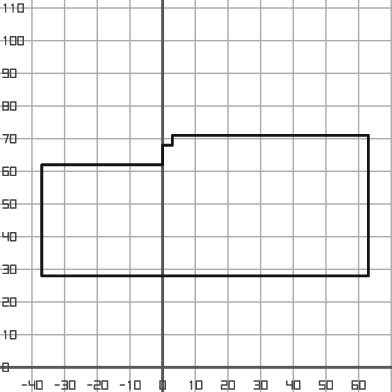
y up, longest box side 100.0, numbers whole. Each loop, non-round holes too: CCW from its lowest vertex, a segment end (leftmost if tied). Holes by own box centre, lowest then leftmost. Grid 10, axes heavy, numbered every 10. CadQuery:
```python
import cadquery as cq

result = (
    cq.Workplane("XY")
    .moveTo(-37.0, 28.0)
    .lineTo(63.0, 28.0)
    .lineTo(63.0, 71.0)
    .lineTo(3.0, 71.0)
    .lineTo(3.0, 68.0)
    .lineTo(0.0, 68.0)
    .lineTo(0.0, 62.0)
    .lineTo(-37.0, 62.0)
    .close()
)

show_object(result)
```